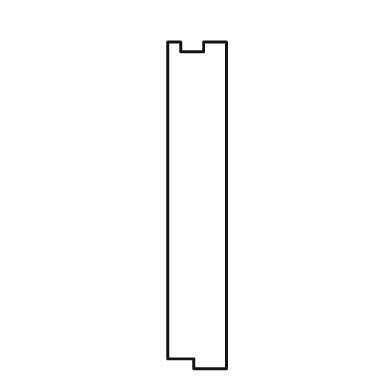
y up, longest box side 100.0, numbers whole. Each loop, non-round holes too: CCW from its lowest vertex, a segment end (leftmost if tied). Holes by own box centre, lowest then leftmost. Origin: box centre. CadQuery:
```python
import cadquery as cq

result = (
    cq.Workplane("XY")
    .moveTo(-1.0, -50.0)
    .lineTo(9.0, -50.0)
    .lineTo(9.0, 50.0)
    .lineTo(2.0, 50.0)
    .lineTo(2.0, 47.0)
    .lineTo(-5.0, 47.0)
    .lineTo(-5.0, 50.0)
    .lineTo(-9.0, 50.0)
    .lineTo(-9.0, -47.0)
    .lineTo(-1.0, -47.0)
    .close()
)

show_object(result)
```